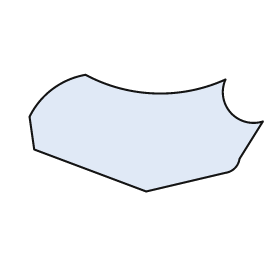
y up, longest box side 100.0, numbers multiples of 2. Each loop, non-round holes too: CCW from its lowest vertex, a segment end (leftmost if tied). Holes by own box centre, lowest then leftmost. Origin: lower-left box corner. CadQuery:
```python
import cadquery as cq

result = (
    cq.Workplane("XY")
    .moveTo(50.0, 0.0)
    .lineTo(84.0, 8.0)
    .threePointArc((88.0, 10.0), (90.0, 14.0))
    .lineTo(100.0, 30.0)
    .threePointArc((86.0, 34.0), (84.0, 48.0))
    .threePointArc((54.0, 42.0), (24.0, 50.0))
    .threePointArc((10.0, 44.0), (0.0, 32.0))
    .lineTo(2.0, 18.0)
    .close()
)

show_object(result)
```